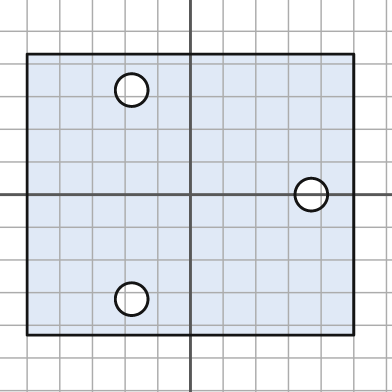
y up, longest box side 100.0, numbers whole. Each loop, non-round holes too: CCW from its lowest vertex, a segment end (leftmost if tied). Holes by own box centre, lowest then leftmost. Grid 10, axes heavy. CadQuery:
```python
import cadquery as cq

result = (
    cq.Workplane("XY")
    .moveTo(-50.0, -43.0)
    .lineTo(50.0, -43.0)
    .lineTo(50.0, 43.0)
    .lineTo(-50.0, 43.0)
    .close()
    .moveTo(-18.0, -32.0)
    .circle(5.0)
    .moveTo(37.0, 0.0)
    .circle(5.0)
    .moveTo(-18.0, 32.0)
    .circle(5.0)
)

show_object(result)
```